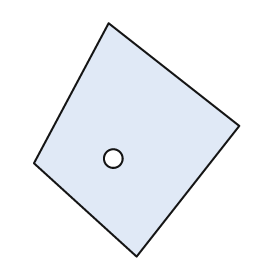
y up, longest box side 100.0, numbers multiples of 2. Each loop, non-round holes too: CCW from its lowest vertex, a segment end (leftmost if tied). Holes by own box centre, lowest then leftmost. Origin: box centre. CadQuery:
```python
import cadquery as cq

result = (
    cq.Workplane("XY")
    .moveTo(0.0, -50.0)
    .lineTo(44.0, 6.0)
    .lineTo(-12.0, 50.0)
    .lineTo(-44.0, -10.0)
    .close()
    .moveTo(-10.0, -8.0)
    .circle(4.0)
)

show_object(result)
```